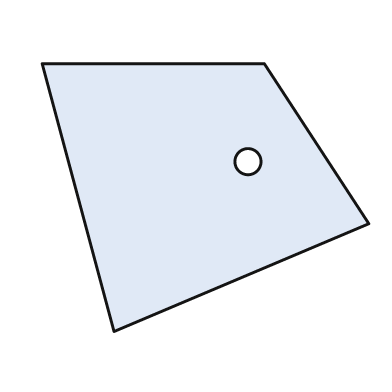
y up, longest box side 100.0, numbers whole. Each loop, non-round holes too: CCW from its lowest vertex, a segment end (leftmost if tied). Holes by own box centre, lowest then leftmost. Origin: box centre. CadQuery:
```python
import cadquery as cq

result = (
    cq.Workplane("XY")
    .moveTo(-28.0, -41.0)
    .lineTo(50.0, -8.0)
    .lineTo(18.0, 41.0)
    .lineTo(-50.0, 41.0)
    .close()
    .moveTo(13.0, 11.0)
    .circle(4.0)
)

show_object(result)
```